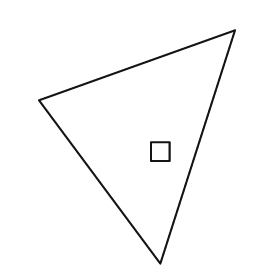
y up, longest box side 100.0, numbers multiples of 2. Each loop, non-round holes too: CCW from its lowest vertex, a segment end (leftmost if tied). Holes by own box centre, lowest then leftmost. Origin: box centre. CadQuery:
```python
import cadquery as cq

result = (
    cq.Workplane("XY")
    .moveTo(10.0, -50.0)
    .lineTo(42.0, 50.0)
    .lineTo(-42.0, 20.0)
    .close()
    .moveTo(6.0, -6.0)
    .lineTo(14.0, -6.0)
    .lineTo(14.0, 2.0)
    .lineTo(6.0, 2.0)
    .close()
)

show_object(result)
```